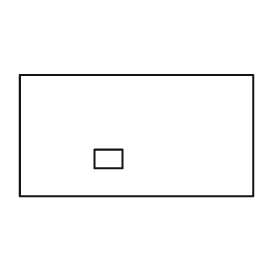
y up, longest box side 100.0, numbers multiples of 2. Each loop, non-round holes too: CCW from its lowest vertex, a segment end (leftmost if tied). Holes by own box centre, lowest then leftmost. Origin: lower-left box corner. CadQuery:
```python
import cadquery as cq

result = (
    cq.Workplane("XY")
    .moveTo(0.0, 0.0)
    .lineTo(100.0, 0.0)
    .lineTo(100.0, 52.0)
    .lineTo(0.0, 52.0)
    .close()
    .moveTo(32.0, 12.0)
    .lineTo(44.0, 12.0)
    .lineTo(44.0, 20.0)
    .lineTo(32.0, 20.0)
    .close()
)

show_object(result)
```